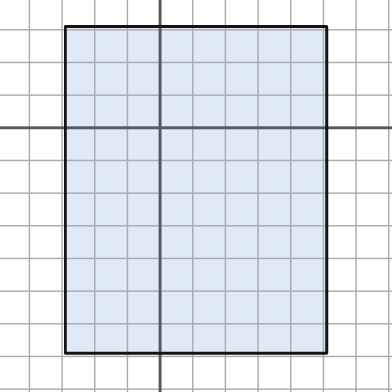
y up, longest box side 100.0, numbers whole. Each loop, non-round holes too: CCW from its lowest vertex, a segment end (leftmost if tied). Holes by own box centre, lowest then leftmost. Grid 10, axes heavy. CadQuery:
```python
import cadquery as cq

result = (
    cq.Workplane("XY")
    .moveTo(-29.0, -69.0)
    .lineTo(51.0, -69.0)
    .lineTo(51.0, 31.0)
    .lineTo(-29.0, 31.0)
    .close()
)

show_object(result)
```